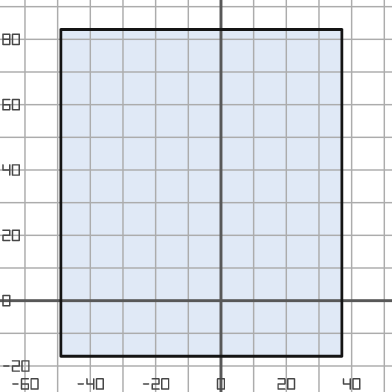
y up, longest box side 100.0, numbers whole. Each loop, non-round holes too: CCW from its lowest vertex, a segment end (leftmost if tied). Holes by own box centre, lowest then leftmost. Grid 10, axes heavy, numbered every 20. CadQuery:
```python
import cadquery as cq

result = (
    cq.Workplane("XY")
    .moveTo(-49.0, -17.0)
    .lineTo(37.0, -17.0)
    .lineTo(37.0, 83.0)
    .lineTo(-49.0, 83.0)
    .close()
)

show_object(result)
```